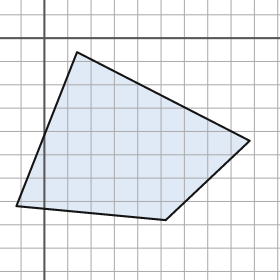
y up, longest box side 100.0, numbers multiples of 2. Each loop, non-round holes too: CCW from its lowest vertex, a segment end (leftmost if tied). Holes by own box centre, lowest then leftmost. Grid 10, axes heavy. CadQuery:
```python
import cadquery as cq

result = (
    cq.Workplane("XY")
    .moveTo(52.0, -78.0)
    .lineTo(88.0, -44.0)
    .lineTo(14.0, -6.0)
    .lineTo(-12.0, -72.0)
    .close()
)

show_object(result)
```